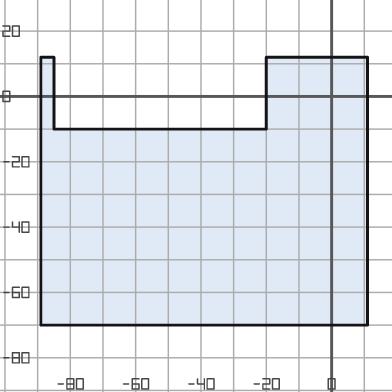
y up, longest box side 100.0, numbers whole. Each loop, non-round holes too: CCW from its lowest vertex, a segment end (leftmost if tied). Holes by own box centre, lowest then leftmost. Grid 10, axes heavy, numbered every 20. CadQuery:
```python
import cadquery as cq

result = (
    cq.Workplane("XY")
    .moveTo(-89.0, -70.0)
    .lineTo(11.0, -70.0)
    .lineTo(11.0, 12.0)
    .lineTo(-20.0, 12.0)
    .lineTo(-20.0, -10.0)
    .lineTo(-85.0, -10.0)
    .lineTo(-85.0, 12.0)
    .lineTo(-89.0, 12.0)
    .close()
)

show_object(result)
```